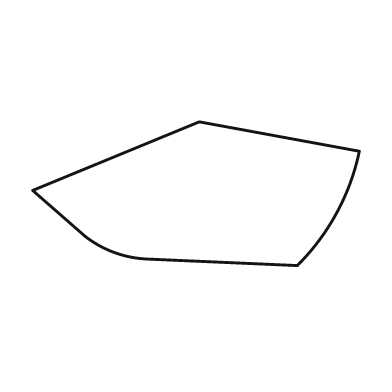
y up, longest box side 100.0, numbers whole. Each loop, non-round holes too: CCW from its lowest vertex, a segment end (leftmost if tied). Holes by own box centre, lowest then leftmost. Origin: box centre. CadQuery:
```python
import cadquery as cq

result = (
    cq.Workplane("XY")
    .moveTo(31.0, -22.0)
    .threePointArc((43.0, -6.0), (50.0, 13.0))
    .lineTo(1.0, 22.0)
    .lineTo(-50.0, 1.0)
    .lineTo(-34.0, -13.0)
    .threePointArc((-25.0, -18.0), (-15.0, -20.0))
    .close()
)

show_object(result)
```